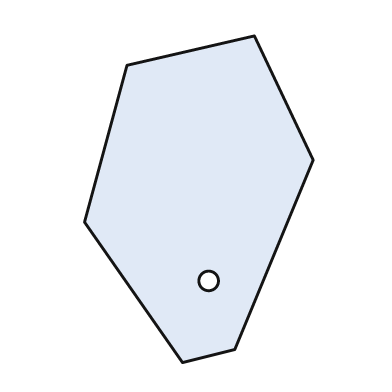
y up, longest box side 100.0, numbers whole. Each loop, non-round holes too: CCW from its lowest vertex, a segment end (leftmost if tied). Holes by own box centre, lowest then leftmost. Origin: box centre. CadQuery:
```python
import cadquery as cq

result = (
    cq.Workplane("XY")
    .moveTo(-5.0, -50.0)
    .lineTo(11.0, -46.0)
    .lineTo(35.0, 12.0)
    .lineTo(17.0, 50.0)
    .lineTo(-22.0, 41.0)
    .lineTo(-35.0, -7.0)
    .close()
    .moveTo(3.0, -25.0)
    .circle(3.0)
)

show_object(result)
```